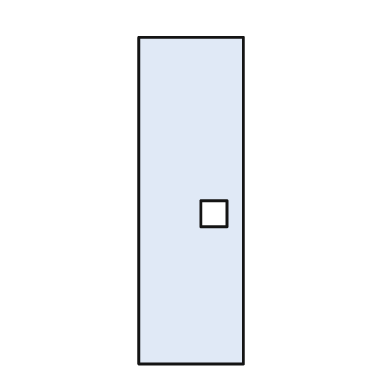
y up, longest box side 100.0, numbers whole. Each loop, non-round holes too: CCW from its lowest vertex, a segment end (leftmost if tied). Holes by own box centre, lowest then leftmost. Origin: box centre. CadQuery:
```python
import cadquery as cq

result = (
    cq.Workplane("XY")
    .moveTo(-16.0, -50.0)
    .lineTo(16.0, -50.0)
    .lineTo(16.0, 50.0)
    .lineTo(-16.0, 50.0)
    .close()
    .moveTo(3.0, -8.0)
    .lineTo(11.0, -8.0)
    .lineTo(11.0, 0.0)
    .lineTo(3.0, 0.0)
    .close()
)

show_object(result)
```